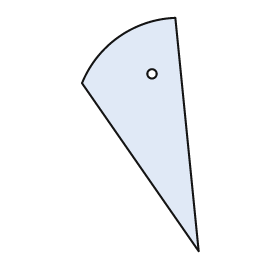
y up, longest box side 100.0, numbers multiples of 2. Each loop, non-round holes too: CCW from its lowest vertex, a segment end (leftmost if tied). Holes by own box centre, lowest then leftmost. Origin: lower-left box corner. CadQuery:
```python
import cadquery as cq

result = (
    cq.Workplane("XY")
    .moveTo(50.0, 0.0)
    .lineTo(40.0, 100.0)
    .threePointArc((16.0, 92.0), (0.0, 72.0))
    .close()
    .moveTo(30.0, 76.0)
    .circle(2.0)
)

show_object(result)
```